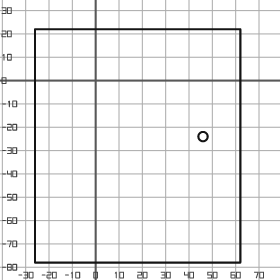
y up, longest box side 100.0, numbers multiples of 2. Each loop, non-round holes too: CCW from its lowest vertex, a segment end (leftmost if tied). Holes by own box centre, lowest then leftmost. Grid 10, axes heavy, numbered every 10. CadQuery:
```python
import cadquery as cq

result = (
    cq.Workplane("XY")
    .moveTo(-26.0, -78.0)
    .lineTo(62.0, -78.0)
    .lineTo(62.0, 22.0)
    .lineTo(-26.0, 22.0)
    .close()
    .moveTo(46.0, -24.0)
    .circle(2.0)
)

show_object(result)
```